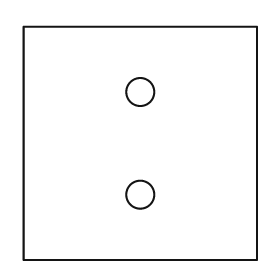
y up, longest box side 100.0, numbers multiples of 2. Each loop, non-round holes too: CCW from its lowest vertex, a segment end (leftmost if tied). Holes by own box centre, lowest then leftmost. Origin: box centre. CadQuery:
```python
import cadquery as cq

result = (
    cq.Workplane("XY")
    .moveTo(-50.0, -50.0)
    .lineTo(50.0, -50.0)
    .lineTo(50.0, 50.0)
    .lineTo(-50.0, 50.0)
    .close()
    .moveTo(0.0, -22.0)
    .circle(6.0)
    .moveTo(0.0, 22.0)
    .circle(6.0)
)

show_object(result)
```